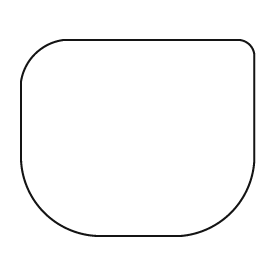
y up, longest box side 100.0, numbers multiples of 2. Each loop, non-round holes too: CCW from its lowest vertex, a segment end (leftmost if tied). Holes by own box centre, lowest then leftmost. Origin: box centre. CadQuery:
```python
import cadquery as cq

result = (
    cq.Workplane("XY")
    .moveTo(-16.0, -42.0)
    .lineTo(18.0, -42.0)
    .threePointArc((40.0, -32.0), (50.0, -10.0))
    .lineTo(50.0, 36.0)
    .threePointArc((48.0, 40.0), (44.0, 42.0))
    .lineTo(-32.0, 42.0)
    .threePointArc((-44.0, 36.0), (-50.0, 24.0))
    .lineTo(-50.0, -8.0)
    .threePointArc((-40.0, -32.0), (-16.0, -42.0))
    .close()
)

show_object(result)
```